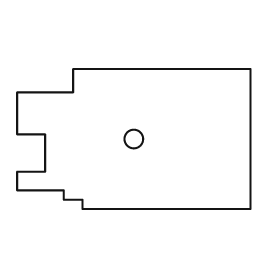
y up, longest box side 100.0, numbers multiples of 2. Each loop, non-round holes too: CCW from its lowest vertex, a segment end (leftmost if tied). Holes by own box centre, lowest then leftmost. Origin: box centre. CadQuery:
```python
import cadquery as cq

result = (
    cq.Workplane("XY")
    .moveTo(-22.0, -30.0)
    .lineTo(50.0, -30.0)
    .lineTo(50.0, 30.0)
    .lineTo(-26.0, 30.0)
    .lineTo(-26.0, 20.0)
    .lineTo(-50.0, 20.0)
    .lineTo(-50.0, 2.0)
    .lineTo(-38.0, 2.0)
    .lineTo(-38.0, -14.0)
    .lineTo(-50.0, -14.0)
    .lineTo(-50.0, -22.0)
    .lineTo(-30.0, -22.0)
    .lineTo(-30.0, -26.0)
    .lineTo(-22.0, -26.0)
    .close()
    .moveTo(0.0, 0.0)
    .circle(4.0)
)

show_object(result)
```